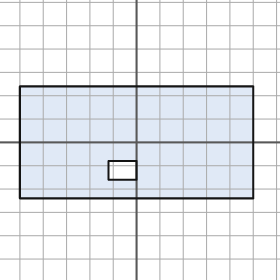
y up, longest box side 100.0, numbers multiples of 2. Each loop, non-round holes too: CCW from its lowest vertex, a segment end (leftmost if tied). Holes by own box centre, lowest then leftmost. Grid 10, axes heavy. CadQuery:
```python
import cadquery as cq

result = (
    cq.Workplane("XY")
    .moveTo(-50.0, -24.0)
    .lineTo(50.0, -24.0)
    .lineTo(50.0, 24.0)
    .lineTo(-50.0, 24.0)
    .close()
    .moveTo(-12.0, -16.0)
    .lineTo(0.0, -16.0)
    .lineTo(0.0, -8.0)
    .lineTo(-12.0, -8.0)
    .close()
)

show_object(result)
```